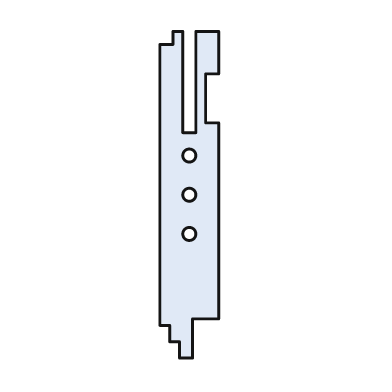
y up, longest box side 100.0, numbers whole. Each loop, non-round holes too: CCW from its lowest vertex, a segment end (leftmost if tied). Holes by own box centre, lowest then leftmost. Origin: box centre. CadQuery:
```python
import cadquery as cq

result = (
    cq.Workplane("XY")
    .moveTo(-3.0, -50.0)
    .lineTo(1.0, -50.0)
    .lineTo(1.0, -38.0)
    .lineTo(9.0, -38.0)
    .lineTo(9.0, 22.0)
    .lineTo(5.0, 22.0)
    .lineTo(5.0, 37.0)
    .lineTo(9.0, 37.0)
    .lineTo(9.0, 50.0)
    .lineTo(2.0, 50.0)
    .lineTo(2.0, 19.0)
    .lineTo(-2.0, 19.0)
    .lineTo(-2.0, 50.0)
    .lineTo(-5.0, 50.0)
    .lineTo(-5.0, 46.0)
    .lineTo(-9.0, 46.0)
    .lineTo(-9.0, -40.0)
    .lineTo(-6.0, -40.0)
    .lineTo(-6.0, -45.0)
    .lineTo(-3.0, -45.0)
    .close()
    .moveTo(0.0, -12.0)
    .circle(2.0)
    .moveTo(0.0, 0.0)
    .circle(2.0)
    .moveTo(0.0, 12.0)
    .circle(2.0)
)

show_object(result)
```